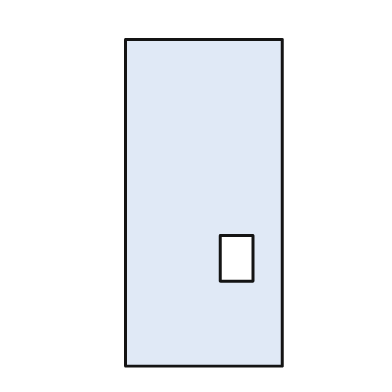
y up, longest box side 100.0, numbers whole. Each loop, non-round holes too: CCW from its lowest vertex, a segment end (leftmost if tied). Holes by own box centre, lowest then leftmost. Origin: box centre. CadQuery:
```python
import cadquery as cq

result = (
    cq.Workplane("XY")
    .moveTo(-24.0, -50.0)
    .lineTo(24.0, -50.0)
    .lineTo(24.0, 50.0)
    .lineTo(-24.0, 50.0)
    .close()
    .moveTo(5.0, -24.0)
    .lineTo(15.0, -24.0)
    .lineTo(15.0, -10.0)
    .lineTo(5.0, -10.0)
    .close()
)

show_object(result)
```